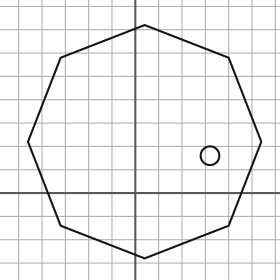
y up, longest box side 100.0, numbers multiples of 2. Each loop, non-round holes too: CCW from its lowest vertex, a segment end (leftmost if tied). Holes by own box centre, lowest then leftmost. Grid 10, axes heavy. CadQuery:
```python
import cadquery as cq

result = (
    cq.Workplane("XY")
    .moveTo(4.0, -28.0)
    .lineTo(40.0, -14.0)
    .lineTo(54.0, 22.0)
    .lineTo(40.0, 58.0)
    .lineTo(4.0, 72.0)
    .lineTo(-32.0, 58.0)
    .lineTo(-46.0, 22.0)
    .lineTo(-32.0, -14.0)
    .close()
    .moveTo(32.0, 16.0)
    .circle(4.0)
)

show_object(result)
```